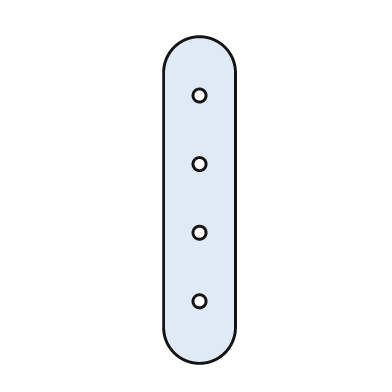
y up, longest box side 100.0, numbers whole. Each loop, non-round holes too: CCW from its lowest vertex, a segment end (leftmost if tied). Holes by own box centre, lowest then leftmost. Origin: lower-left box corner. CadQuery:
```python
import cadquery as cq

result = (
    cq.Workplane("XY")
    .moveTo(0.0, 11.0)
    .threePointArc((11.0, 0.0), (22.0, 11.0))
    .lineTo(22.0, 89.0)
    .threePointArc((11.0, 100.0), (0.0, 89.0))
    .close()
    .moveTo(11.0, 19.0)
    .circle(2.0)
    .moveTo(11.0, 40.0)
    .circle(2.0)
    .moveTo(11.0, 61.0)
    .circle(2.0)
    .moveTo(11.0, 82.0)
    .circle(2.0)
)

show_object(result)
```